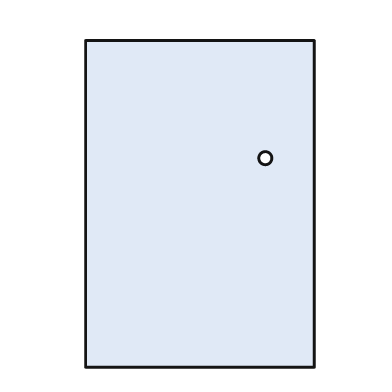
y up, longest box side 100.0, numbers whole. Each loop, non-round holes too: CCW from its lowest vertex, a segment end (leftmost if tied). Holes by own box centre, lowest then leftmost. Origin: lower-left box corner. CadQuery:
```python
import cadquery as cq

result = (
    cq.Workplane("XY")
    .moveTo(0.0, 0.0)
    .lineTo(70.0, 0.0)
    .lineTo(70.0, 100.0)
    .lineTo(0.0, 100.0)
    .close()
    .moveTo(55.0, 64.0)
    .circle(2.0)
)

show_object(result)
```